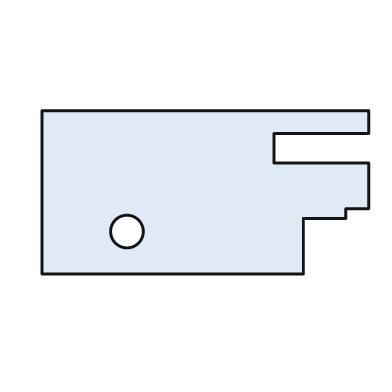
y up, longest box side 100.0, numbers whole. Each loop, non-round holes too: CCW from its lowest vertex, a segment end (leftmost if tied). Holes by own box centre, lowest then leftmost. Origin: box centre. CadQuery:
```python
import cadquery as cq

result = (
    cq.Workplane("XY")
    .moveTo(-50.0, -25.0)
    .lineTo(30.0, -25.0)
    .lineTo(30.0, -8.0)
    .lineTo(43.0, -8.0)
    .lineTo(43.0, -5.0)
    .lineTo(50.0, -5.0)
    .lineTo(50.0, 9.0)
    .lineTo(21.0, 9.0)
    .lineTo(21.0, 18.0)
    .lineTo(50.0, 18.0)
    .lineTo(50.0, 25.0)
    .lineTo(-50.0, 25.0)
    .close()
    .moveTo(-24.0, -12.0)
    .circle(5.0)
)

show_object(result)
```